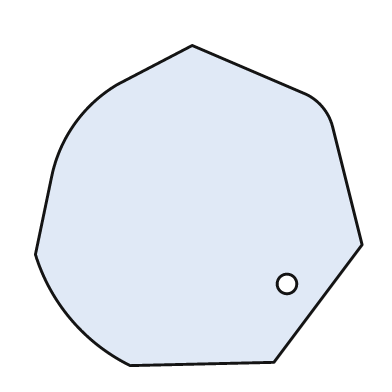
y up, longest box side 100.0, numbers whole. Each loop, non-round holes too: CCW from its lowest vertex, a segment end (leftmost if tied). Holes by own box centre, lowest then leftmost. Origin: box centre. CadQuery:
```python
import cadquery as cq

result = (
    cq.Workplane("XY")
    .moveTo(-21.0, -49.0)
    .lineTo(23.0, -48.0)
    .lineTo(50.0, -12.0)
    .lineTo(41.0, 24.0)
    .threePointArc((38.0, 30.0), (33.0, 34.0))
    .lineTo(-2.0, 49.0)
    .lineTo(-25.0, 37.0)
    .threePointArc((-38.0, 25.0), (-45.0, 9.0))
    .lineTo(-50.0, -15.0)
    .threePointArc((-39.0, -35.0), (-21.0, -49.0))
    .close()
    .moveTo(27.0, -24.0)
    .circle(3.0)
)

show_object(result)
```